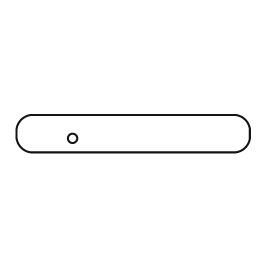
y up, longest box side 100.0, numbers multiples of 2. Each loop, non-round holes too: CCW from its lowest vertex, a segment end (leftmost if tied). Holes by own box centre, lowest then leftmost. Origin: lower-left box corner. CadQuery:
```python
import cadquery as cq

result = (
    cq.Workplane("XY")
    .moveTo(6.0, 0.0)
    .lineTo(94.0, 0.0)
    .threePointArc((98.0, 2.0), (100.0, 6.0))
    .lineTo(100.0, 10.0)
    .threePointArc((98.0, 14.0), (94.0, 16.0))
    .lineTo(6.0, 16.0)
    .threePointArc((2.0, 14.0), (0.0, 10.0))
    .lineTo(0.0, 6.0)
    .threePointArc((2.0, 2.0), (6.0, 0.0))
    .close()
    .moveTo(24.0, 6.0)
    .circle(2.0)
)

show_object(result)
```